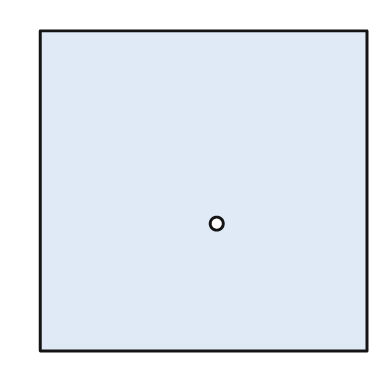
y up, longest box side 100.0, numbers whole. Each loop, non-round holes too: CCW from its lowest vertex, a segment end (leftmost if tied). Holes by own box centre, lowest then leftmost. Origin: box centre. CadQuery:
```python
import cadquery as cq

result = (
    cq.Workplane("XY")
    .moveTo(-50.0, -49.0)
    .lineTo(50.0, -49.0)
    .lineTo(50.0, 49.0)
    .lineTo(-50.0, 49.0)
    .close()
    .moveTo(4.0, -10.0)
    .circle(2.0)
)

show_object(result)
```